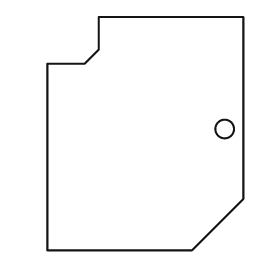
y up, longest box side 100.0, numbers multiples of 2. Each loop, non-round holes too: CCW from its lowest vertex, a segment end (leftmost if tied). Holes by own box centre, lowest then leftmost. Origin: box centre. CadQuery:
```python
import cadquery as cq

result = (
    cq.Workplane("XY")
    .moveTo(-42.0, -50.0)
    .lineTo(20.0, -50.0)
    .lineTo(42.0, -28.0)
    .lineTo(42.0, 50.0)
    .lineTo(-20.0, 50.0)
    .lineTo(-20.0, 36.0)
    .lineTo(-26.0, 30.0)
    .lineTo(-42.0, 30.0)
    .close()
    .moveTo(34.0, 2.0)
    .circle(4.0)
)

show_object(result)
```